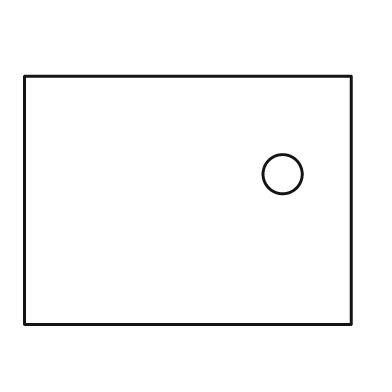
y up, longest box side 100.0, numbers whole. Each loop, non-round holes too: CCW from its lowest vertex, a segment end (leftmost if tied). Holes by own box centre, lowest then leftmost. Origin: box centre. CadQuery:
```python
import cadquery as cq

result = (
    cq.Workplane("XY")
    .moveTo(-50.0, -38.0)
    .lineTo(50.0, -38.0)
    .lineTo(50.0, 38.0)
    .lineTo(-50.0, 38.0)
    .close()
    .moveTo(29.0, 8.0)
    .circle(6.0)
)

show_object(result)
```